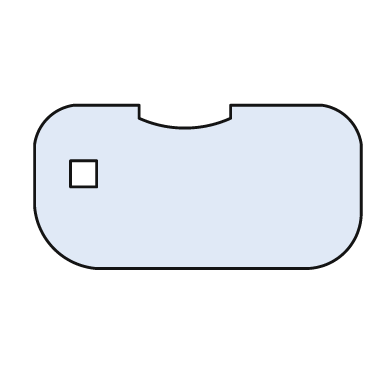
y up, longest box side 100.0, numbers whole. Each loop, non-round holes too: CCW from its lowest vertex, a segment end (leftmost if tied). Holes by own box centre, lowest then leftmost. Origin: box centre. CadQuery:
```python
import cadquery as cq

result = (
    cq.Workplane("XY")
    .moveTo(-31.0, -25.0)
    .lineTo(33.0, -25.0)
    .threePointArc((45.0, -20.0), (50.0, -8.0))
    .lineTo(50.0, 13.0)
    .threePointArc((46.0, 21.0), (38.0, 25.0))
    .lineTo(10.0, 25.0)
    .lineTo(10.0, 21.0)
    .threePointArc((-4.0, 18.0), (-18.0, 21.0))
    .lineTo(-18.0, 25.0)
    .lineTo(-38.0, 25.0)
    .threePointArc((-46.0, 21.0), (-50.0, 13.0))
    .lineTo(-50.0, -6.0)
    .threePointArc((-44.0, -19.0), (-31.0, -25.0))
    .close()
    .moveTo(-39.0, 0.0)
    .lineTo(-31.0, 0.0)
    .lineTo(-31.0, 8.0)
    .lineTo(-39.0, 8.0)
    .close()
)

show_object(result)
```